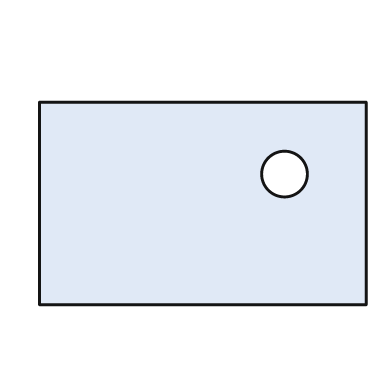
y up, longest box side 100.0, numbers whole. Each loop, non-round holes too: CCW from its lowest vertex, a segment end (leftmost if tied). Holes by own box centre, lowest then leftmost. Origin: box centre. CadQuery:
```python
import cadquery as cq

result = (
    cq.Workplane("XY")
    .moveTo(-50.0, -31.0)
    .lineTo(50.0, -31.0)
    .lineTo(50.0, 31.0)
    .lineTo(-50.0, 31.0)
    .close()
    .moveTo(25.0, 9.0)
    .circle(7.0)
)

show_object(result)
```